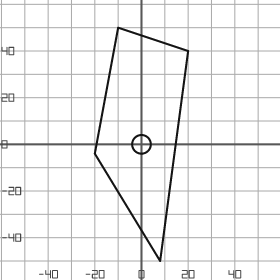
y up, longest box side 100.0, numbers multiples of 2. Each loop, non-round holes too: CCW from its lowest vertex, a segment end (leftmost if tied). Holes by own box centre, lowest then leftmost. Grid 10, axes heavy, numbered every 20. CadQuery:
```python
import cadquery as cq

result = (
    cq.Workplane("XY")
    .moveTo(8.0, -50.0)
    .lineTo(20.0, 40.0)
    .lineTo(-10.0, 50.0)
    .lineTo(-20.0, -4.0)
    .close()
    .moveTo(0.0, 0.0)
    .circle(4.0)
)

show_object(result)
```